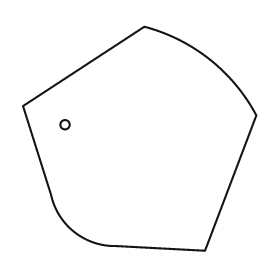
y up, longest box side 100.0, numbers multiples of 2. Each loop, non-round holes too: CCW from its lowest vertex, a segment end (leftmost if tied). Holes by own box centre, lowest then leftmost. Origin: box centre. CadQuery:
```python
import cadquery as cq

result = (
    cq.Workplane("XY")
    .moveTo(28.0, -48.0)
    .lineTo(50.0, 10.0)
    .threePointArc((30.0, 34.0), (2.0, 48.0))
    .lineTo(-50.0, 14.0)
    .lineTo(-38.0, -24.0)
    .threePointArc((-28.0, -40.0), (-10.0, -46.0))
    .close()
    .moveTo(-32.0, 6.0)
    .circle(2.0)
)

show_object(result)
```